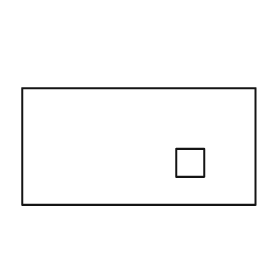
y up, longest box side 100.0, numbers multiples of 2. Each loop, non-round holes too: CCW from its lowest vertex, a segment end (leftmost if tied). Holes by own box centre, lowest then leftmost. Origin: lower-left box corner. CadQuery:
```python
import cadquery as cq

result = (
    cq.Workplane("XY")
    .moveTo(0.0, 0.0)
    .lineTo(100.0, 0.0)
    .lineTo(100.0, 50.0)
    .lineTo(0.0, 50.0)
    .close()
    .moveTo(66.0, 12.0)
    .lineTo(78.0, 12.0)
    .lineTo(78.0, 24.0)
    .lineTo(66.0, 24.0)
    .close()
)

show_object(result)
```